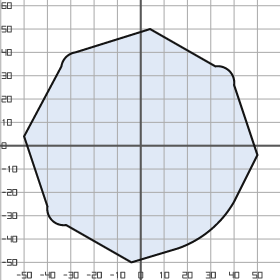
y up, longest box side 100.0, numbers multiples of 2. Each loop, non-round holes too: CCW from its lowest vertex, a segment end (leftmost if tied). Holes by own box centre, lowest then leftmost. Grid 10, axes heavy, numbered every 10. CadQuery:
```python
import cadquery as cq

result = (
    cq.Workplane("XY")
    .moveTo(-4.0, -50.0)
    .lineTo(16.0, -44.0)
    .threePointArc((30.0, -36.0), (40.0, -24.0))
    .lineTo(50.0, -4.0)
    .lineTo(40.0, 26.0)
    .threePointArc((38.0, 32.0), (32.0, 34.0))
    .lineTo(4.0, 50.0)
    .lineTo(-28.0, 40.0)
    .threePointArc((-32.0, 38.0), (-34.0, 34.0))
    .lineTo(-50.0, 4.0)
    .lineTo(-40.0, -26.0)
    .threePointArc((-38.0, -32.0), (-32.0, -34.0))
    .close()
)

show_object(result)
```